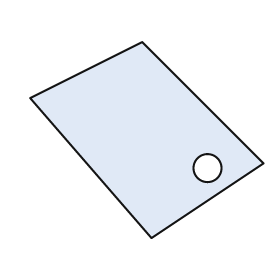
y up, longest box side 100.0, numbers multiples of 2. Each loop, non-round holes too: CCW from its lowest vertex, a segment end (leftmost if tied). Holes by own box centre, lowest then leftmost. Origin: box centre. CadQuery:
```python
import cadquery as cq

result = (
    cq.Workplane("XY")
    .moveTo(2.0, -42.0)
    .lineTo(50.0, -10.0)
    .lineTo(-2.0, 42.0)
    .lineTo(-50.0, 18.0)
    .close()
    .moveTo(26.0, -12.0)
    .circle(6.0)
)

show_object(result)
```